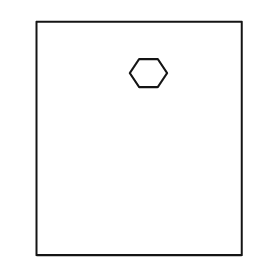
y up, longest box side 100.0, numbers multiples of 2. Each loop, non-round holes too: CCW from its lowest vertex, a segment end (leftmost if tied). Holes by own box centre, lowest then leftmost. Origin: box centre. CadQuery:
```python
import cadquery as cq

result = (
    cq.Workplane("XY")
    .moveTo(-44.0, -50.0)
    .lineTo(44.0, -50.0)
    .lineTo(44.0, 50.0)
    .lineTo(-44.0, 50.0)
    .close()
    .moveTo(0.0, 22.0)
    .lineTo(8.0, 22.0)
    .lineTo(12.0, 28.0)
    .lineTo(8.0, 34.0)
    .lineTo(0.0, 34.0)
    .lineTo(-4.0, 28.0)
    .close()
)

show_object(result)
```